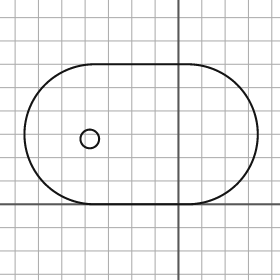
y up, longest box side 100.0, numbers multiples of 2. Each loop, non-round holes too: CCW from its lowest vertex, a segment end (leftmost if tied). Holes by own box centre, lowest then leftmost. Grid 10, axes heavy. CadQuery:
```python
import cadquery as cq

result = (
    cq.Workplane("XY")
    .moveTo(-36.0, 0.0)
    .lineTo(4.0, 0.0)
    .threePointArc((34.0, 30.0), (4.0, 60.0))
    .lineTo(-36.0, 60.0)
    .threePointArc((-66.0, 30.0), (-36.0, 0.0))
    .close()
    .moveTo(-38.0, 28.0)
    .circle(4.0)
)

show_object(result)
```